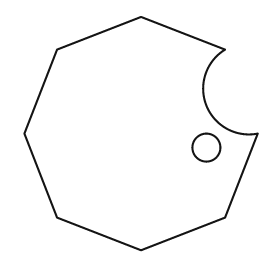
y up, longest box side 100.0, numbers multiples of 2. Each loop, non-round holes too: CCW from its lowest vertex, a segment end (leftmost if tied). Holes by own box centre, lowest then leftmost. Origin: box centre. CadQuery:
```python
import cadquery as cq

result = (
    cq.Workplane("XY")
    .moveTo(0.0, -50.0)
    .lineTo(36.0, -36.0)
    .lineTo(50.0, 0.0)
    .threePointArc((28.0, 12.0), (36.0, 36.0))
    .lineTo(0.0, 50.0)
    .lineTo(-36.0, 36.0)
    .lineTo(-50.0, 0.0)
    .lineTo(-36.0, -36.0)
    .close()
    .moveTo(28.0, -6.0)
    .circle(6.0)
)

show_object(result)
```